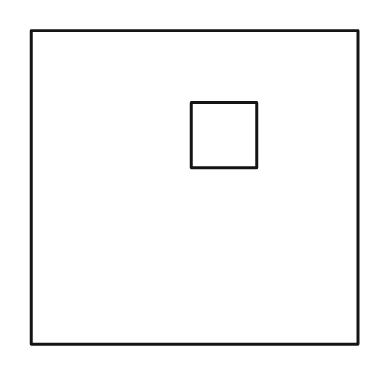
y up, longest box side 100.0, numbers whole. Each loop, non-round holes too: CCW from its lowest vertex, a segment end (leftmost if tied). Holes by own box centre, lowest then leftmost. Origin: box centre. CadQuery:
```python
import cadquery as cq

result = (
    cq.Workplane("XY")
    .moveTo(-50.0, -48.0)
    .lineTo(50.0, -48.0)
    .lineTo(50.0, 48.0)
    .lineTo(-50.0, 48.0)
    .close()
    .moveTo(-1.0, 6.0)
    .lineTo(19.0, 6.0)
    .lineTo(19.0, 26.0)
    .lineTo(-1.0, 26.0)
    .close()
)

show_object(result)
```